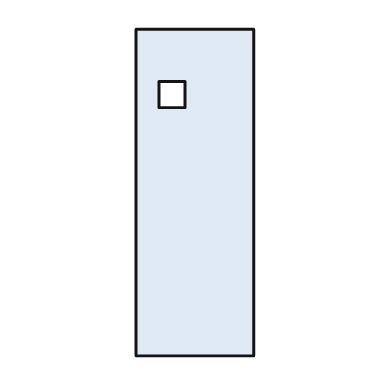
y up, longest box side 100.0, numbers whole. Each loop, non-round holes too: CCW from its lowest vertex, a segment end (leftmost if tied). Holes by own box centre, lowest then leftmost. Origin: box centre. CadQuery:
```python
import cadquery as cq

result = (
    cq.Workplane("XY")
    .moveTo(-18.0, -50.0)
    .lineTo(18.0, -50.0)
    .lineTo(18.0, 50.0)
    .lineTo(-18.0, 50.0)
    .close()
    .moveTo(-11.0, 26.0)
    .lineTo(-3.0, 26.0)
    .lineTo(-3.0, 34.0)
    .lineTo(-11.0, 34.0)
    .close()
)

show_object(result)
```